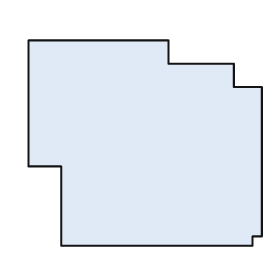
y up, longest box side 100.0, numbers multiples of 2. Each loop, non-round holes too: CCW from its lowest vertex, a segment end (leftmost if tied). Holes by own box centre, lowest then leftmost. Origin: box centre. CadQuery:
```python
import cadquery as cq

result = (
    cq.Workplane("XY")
    .moveTo(-36.0, -44.0)
    .lineTo(46.0, -44.0)
    .lineTo(46.0, -40.0)
    .lineTo(50.0, -40.0)
    .lineTo(50.0, 24.0)
    .lineTo(38.0, 24.0)
    .lineTo(38.0, 34.0)
    .lineTo(10.0, 34.0)
    .lineTo(10.0, 44.0)
    .lineTo(-50.0, 44.0)
    .lineTo(-50.0, -10.0)
    .lineTo(-36.0, -10.0)
    .close()
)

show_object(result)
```